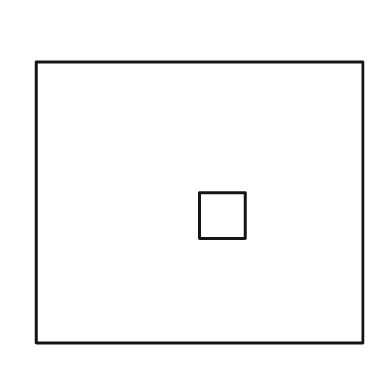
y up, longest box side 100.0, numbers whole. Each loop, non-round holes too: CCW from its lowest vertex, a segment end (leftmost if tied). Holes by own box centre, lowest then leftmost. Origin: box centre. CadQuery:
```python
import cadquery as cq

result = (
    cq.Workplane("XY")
    .moveTo(-50.0, -43.0)
    .lineTo(50.0, -43.0)
    .lineTo(50.0, 43.0)
    .lineTo(-50.0, 43.0)
    .close()
    .moveTo(0.0, -11.0)
    .lineTo(14.0, -11.0)
    .lineTo(14.0, 3.0)
    .lineTo(0.0, 3.0)
    .close()
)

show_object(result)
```